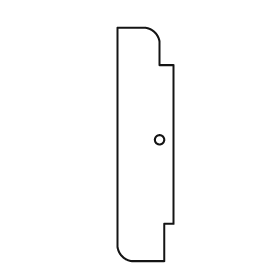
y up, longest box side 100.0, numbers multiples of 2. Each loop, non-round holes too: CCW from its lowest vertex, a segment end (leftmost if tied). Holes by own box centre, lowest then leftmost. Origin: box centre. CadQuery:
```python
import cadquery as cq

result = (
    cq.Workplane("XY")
    .moveTo(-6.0, -50.0)
    .lineTo(8.0, -50.0)
    .lineTo(8.0, -34.0)
    .lineTo(12.0, -34.0)
    .lineTo(12.0, 34.0)
    .lineTo(6.0, 34.0)
    .lineTo(6.0, 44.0)
    .threePointArc((4.0, 48.0), (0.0, 50.0))
    .lineTo(-12.0, 50.0)
    .lineTo(-12.0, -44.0)
    .threePointArc((-10.0, -48.0), (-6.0, -50.0))
    .close()
    .moveTo(6.0, 2.0)
    .circle(2.0)
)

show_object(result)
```